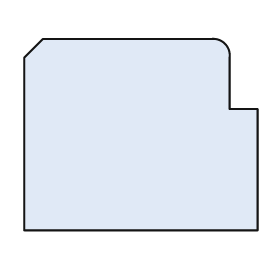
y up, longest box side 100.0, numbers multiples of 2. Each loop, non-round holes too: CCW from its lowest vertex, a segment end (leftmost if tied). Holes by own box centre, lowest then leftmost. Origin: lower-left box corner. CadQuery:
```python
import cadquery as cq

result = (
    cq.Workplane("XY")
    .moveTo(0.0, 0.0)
    .lineTo(100.0, 0.0)
    .lineTo(100.0, 52.0)
    .lineTo(88.0, 52.0)
    .lineTo(88.0, 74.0)
    .threePointArc((86.0, 80.0), (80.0, 82.0))
    .lineTo(8.0, 82.0)
    .lineTo(0.0, 74.0)
    .close()
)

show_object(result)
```